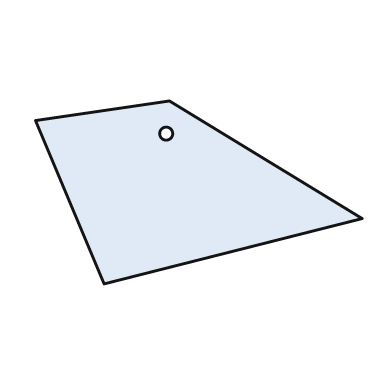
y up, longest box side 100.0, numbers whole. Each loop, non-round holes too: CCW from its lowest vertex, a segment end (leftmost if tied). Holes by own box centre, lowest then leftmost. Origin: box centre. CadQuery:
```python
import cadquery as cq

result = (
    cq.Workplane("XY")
    .moveTo(-29.0, -28.0)
    .lineTo(50.0, -8.0)
    .lineTo(-9.0, 28.0)
    .lineTo(-50.0, 22.0)
    .close()
    .moveTo(-10.0, 18.0)
    .circle(2.0)
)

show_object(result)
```